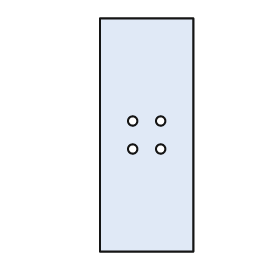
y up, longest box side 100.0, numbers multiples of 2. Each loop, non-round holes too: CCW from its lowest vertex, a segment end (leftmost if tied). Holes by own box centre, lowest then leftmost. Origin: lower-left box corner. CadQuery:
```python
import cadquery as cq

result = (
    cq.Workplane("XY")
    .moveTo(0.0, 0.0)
    .lineTo(40.0, 0.0)
    .lineTo(40.0, 100.0)
    .lineTo(0.0, 100.0)
    .close()
    .moveTo(14.0, 44.0)
    .circle(2.0)
    .moveTo(26.0, 44.0)
    .circle(2.0)
    .moveTo(14.0, 56.0)
    .circle(2.0)
    .moveTo(26.0, 56.0)
    .circle(2.0)
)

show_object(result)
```